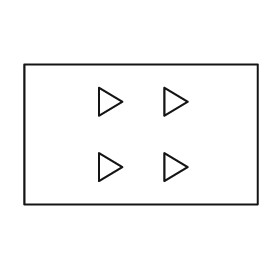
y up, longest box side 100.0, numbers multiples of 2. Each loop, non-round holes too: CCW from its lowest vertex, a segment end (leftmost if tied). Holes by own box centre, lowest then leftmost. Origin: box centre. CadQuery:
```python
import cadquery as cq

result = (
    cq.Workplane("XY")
    .moveTo(-50.0, -30.0)
    .lineTo(50.0, -30.0)
    .lineTo(50.0, 30.0)
    .lineTo(-50.0, 30.0)
    .close()
    .moveTo(-18.0, -20.0)
    .lineTo(-8.0, -14.0)
    .lineTo(-18.0, -8.0)
    .close()
    .moveTo(10.0, -20.0)
    .lineTo(20.0, -14.0)
    .lineTo(10.0, -8.0)
    .close()
    .moveTo(-18.0, 8.0)
    .lineTo(-8.0, 14.0)
    .lineTo(-18.0, 20.0)
    .close()
    .moveTo(10.0, 8.0)
    .lineTo(20.0, 14.0)
    .lineTo(10.0, 20.0)
    .close()
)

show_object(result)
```